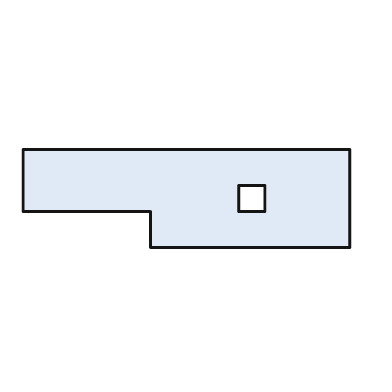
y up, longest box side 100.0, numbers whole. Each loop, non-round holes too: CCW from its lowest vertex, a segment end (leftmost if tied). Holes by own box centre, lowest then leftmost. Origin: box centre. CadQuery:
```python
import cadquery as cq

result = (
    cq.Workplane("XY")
    .moveTo(-11.0, -15.0)
    .lineTo(50.0, -15.0)
    .lineTo(50.0, 15.0)
    .lineTo(-50.0, 15.0)
    .lineTo(-50.0, -4.0)
    .lineTo(-11.0, -4.0)
    .close()
    .moveTo(16.0, -4.0)
    .lineTo(24.0, -4.0)
    .lineTo(24.0, 4.0)
    .lineTo(16.0, 4.0)
    .close()
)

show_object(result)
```